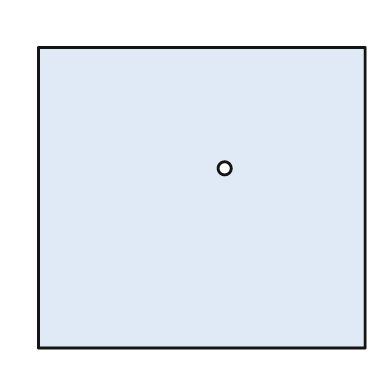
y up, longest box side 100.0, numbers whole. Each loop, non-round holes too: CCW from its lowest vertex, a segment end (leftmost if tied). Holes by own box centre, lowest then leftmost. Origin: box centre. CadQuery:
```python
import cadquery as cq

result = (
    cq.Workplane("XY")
    .moveTo(-50.0, -46.0)
    .lineTo(50.0, -46.0)
    .lineTo(50.0, 46.0)
    .lineTo(-50.0, 46.0)
    .close()
    .moveTo(7.0, 9.0)
    .circle(2.0)
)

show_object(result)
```